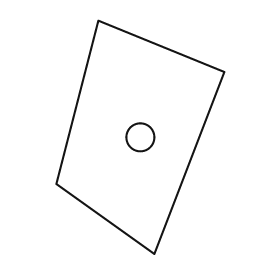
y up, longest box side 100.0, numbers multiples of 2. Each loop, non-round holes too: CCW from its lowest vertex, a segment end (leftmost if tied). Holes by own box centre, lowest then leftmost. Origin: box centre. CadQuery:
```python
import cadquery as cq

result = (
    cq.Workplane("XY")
    .moveTo(6.0, -50.0)
    .lineTo(36.0, 28.0)
    .lineTo(-18.0, 50.0)
    .lineTo(-36.0, -20.0)
    .close()
    .moveTo(0.0, 0.0)
    .circle(6.0)
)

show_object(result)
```